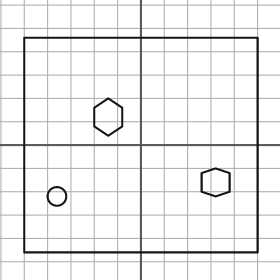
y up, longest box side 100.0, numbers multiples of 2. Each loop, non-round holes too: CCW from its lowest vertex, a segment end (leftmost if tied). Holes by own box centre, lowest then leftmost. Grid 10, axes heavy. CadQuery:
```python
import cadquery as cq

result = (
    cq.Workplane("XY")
    .moveTo(-50.0, -46.0)
    .lineTo(50.0, -46.0)
    .lineTo(50.0, 46.0)
    .lineTo(-50.0, 46.0)
    .close()
    .moveTo(-36.0, -22.0)
    .circle(4.0)
    .moveTo(32.0, -22.0)
    .lineTo(38.0, -20.0)
    .lineTo(38.0, -12.0)
    .lineTo(32.0, -10.0)
    .lineTo(26.0, -12.0)
    .lineTo(26.0, -20.0)
    .close()
    .moveTo(-14.0, 4.0)
    .lineTo(-8.0, 8.0)
    .lineTo(-8.0, 16.0)
    .lineTo(-14.0, 20.0)
    .lineTo(-20.0, 16.0)
    .lineTo(-20.0, 8.0)
    .close()
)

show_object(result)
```